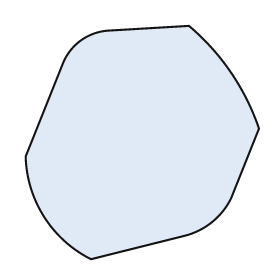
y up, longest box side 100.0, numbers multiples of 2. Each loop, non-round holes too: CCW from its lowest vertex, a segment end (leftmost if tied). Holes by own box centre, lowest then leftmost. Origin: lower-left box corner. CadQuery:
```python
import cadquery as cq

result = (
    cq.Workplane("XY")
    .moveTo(28.0, 0.0)
    .lineTo(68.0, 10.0)
    .threePointArc((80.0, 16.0), (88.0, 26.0))
    .lineTo(100.0, 56.0)
    .threePointArc((88.0, 80.0), (70.0, 100.0))
    .lineTo(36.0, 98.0)
    .threePointArc((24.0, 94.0), (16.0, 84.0))
    .lineTo(0.0, 44.0)
    .threePointArc((8.0, 18.0), (28.0, 0.0))
    .close()
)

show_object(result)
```